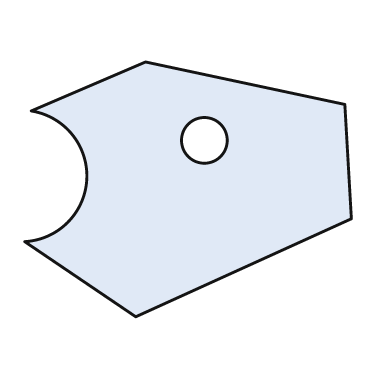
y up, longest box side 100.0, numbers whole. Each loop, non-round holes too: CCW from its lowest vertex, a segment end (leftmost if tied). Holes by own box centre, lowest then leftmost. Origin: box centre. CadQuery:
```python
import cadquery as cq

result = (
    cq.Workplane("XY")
    .moveTo(-16.0, -39.0)
    .lineTo(50.0, -9.0)
    .lineTo(48.0, 26.0)
    .lineTo(-13.0, 39.0)
    .lineTo(-48.0, 24.0)
    .threePointArc((-31.0, 3.0), (-50.0, -16.0))
    .close()
    .moveTo(5.0, 15.0)
    .circle(7.0)
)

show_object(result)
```